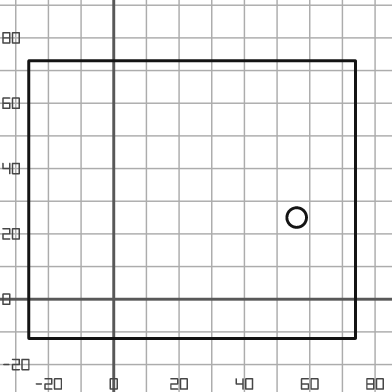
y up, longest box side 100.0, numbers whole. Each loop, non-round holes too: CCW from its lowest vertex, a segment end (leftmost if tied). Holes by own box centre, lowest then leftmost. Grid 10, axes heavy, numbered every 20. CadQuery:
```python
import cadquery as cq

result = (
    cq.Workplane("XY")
    .moveTo(-26.0, -12.0)
    .lineTo(74.0, -12.0)
    .lineTo(74.0, 73.0)
    .lineTo(-26.0, 73.0)
    .close()
    .moveTo(56.0, 25.0)
    .circle(3.0)
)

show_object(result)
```